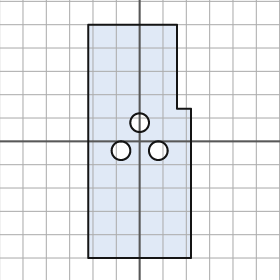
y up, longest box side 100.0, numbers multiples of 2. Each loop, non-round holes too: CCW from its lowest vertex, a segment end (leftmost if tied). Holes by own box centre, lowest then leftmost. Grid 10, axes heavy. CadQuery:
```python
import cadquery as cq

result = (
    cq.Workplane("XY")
    .moveTo(-22.0, -50.0)
    .lineTo(22.0, -50.0)
    .lineTo(22.0, 14.0)
    .lineTo(16.0, 14.0)
    .lineTo(16.0, 50.0)
    .lineTo(-22.0, 50.0)
    .close()
    .moveTo(-8.0, -4.0)
    .circle(4.0)
    .moveTo(8.0, -4.0)
    .circle(4.0)
    .moveTo(0.0, 8.0)
    .circle(4.0)
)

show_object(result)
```